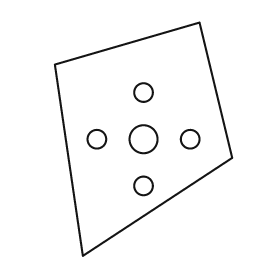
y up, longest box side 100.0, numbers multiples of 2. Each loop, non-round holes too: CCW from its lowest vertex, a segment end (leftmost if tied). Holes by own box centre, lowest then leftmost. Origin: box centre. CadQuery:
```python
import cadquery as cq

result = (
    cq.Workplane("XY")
    .moveTo(-26.0, -50.0)
    .lineTo(38.0, -8.0)
    .lineTo(24.0, 50.0)
    .lineTo(-38.0, 32.0)
    .close()
    .moveTo(0.0, -20.0)
    .circle(4.0)
    .moveTo(-20.0, 0.0)
    .circle(4.0)
    .moveTo(0.0, 0.0)
    .circle(6.0)
    .moveTo(20.0, 0.0)
    .circle(4.0)
    .moveTo(0.0, 20.0)
    .circle(4.0)
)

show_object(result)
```